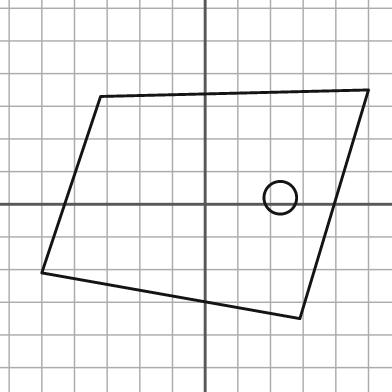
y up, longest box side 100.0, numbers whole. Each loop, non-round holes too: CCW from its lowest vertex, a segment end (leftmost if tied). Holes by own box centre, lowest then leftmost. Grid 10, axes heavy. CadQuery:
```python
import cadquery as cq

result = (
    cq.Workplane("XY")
    .moveTo(29.0, -35.0)
    .lineTo(50.0, 35.0)
    .lineTo(-32.0, 33.0)
    .lineTo(-50.0, -21.0)
    .close()
    .moveTo(23.0, 2.0)
    .circle(5.0)
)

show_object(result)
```